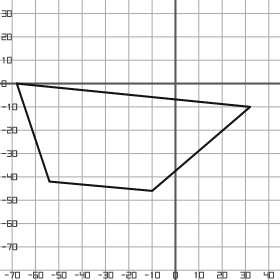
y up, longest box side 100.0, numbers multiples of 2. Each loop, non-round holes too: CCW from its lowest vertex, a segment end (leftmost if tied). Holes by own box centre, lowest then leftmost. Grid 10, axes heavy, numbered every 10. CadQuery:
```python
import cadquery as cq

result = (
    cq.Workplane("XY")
    .moveTo(-10.0, -46.0)
    .lineTo(32.0, -10.0)
    .lineTo(-68.0, 0.0)
    .lineTo(-54.0, -42.0)
    .close()
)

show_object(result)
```